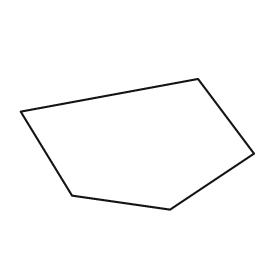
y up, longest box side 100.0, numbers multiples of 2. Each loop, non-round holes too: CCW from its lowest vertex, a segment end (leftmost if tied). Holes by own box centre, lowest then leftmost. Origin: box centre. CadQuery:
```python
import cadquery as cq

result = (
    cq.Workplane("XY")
    .moveTo(14.0, -28.0)
    .lineTo(50.0, -4.0)
    .lineTo(26.0, 28.0)
    .lineTo(-50.0, 14.0)
    .lineTo(-28.0, -22.0)
    .close()
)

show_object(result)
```